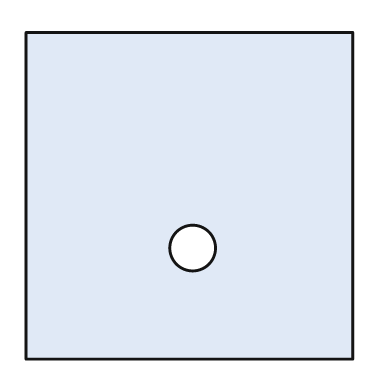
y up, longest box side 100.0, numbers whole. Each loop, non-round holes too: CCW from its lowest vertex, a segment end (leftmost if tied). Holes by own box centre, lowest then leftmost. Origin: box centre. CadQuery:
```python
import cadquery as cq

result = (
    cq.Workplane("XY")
    .moveTo(-50.0, -50.0)
    .lineTo(50.0, -50.0)
    .lineTo(50.0, 50.0)
    .lineTo(-50.0, 50.0)
    .close()
    .moveTo(1.0, -16.0)
    .circle(7.0)
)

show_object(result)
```